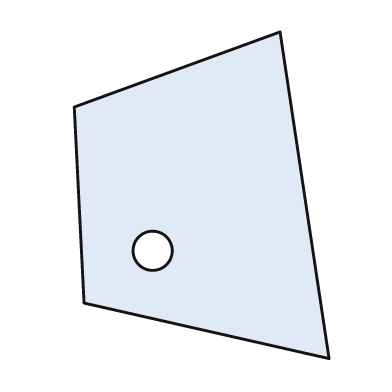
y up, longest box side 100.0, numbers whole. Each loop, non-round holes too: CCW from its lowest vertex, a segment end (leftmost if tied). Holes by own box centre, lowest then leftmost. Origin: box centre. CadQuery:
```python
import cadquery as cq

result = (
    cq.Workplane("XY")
    .moveTo(39.0, -50.0)
    .lineTo(24.0, 50.0)
    .lineTo(-39.0, 27.0)
    .lineTo(-36.0, -33.0)
    .close()
    .moveTo(-15.0, -17.0)
    .circle(6.0)
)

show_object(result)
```